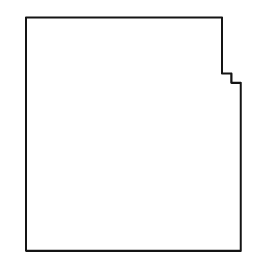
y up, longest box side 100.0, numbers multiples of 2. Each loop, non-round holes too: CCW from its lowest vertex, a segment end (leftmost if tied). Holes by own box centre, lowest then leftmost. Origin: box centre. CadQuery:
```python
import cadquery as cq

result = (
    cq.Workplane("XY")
    .moveTo(-46.0, -50.0)
    .lineTo(46.0, -50.0)
    .lineTo(46.0, 22.0)
    .lineTo(42.0, 22.0)
    .lineTo(42.0, 26.0)
    .lineTo(38.0, 26.0)
    .lineTo(38.0, 50.0)
    .lineTo(-46.0, 50.0)
    .close()
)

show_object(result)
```